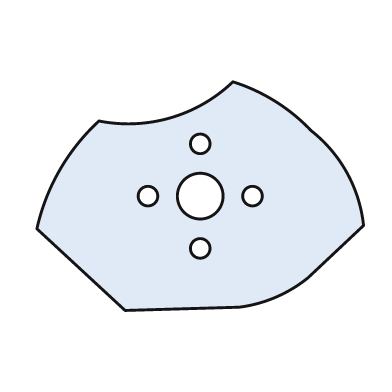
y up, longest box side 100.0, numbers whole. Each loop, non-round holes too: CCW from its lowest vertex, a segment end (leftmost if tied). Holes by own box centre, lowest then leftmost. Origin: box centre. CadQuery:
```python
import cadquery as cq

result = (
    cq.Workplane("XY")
    .moveTo(-23.0, -35.0)
    .lineTo(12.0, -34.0)
    .threePointArc((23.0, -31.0), (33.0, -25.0))
    .lineTo(50.0, -9.0)
    .threePointArc((45.0, 7.0), (34.0, 20.0))
    .threePointArc((23.0, 29.0), (10.0, 35.0))
    .threePointArc((-9.0, 24.0), (-31.0, 23.0))
    .threePointArc((-43.0, 8.0), (-50.0, -10.0))
    .close()
    .moveTo(0.0, -16.0)
    .circle(3.0)
    .moveTo(-16.0, 0.0)
    .circle(3.0)
    .moveTo(0.0, 0.0)
    .circle(7.0)
    .moveTo(16.0, 0.0)
    .circle(3.0)
    .moveTo(0.0, 16.0)
    .circle(3.0)
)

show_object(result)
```